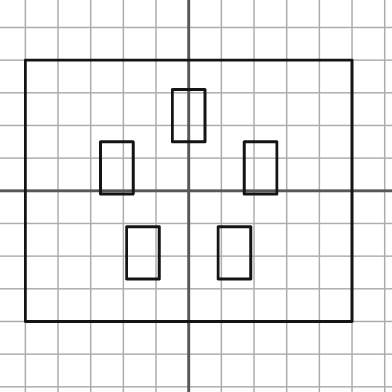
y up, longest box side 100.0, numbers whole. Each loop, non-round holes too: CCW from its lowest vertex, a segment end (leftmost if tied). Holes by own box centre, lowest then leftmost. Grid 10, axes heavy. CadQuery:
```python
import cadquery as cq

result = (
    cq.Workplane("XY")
    .moveTo(-50.0, -40.0)
    .lineTo(50.0, -40.0)
    .lineTo(50.0, 40.0)
    .lineTo(-50.0, 40.0)
    .close()
    .moveTo(-19.0, -27.0)
    .lineTo(-9.0, -27.0)
    .lineTo(-9.0, -11.0)
    .lineTo(-19.0, -11.0)
    .close()
    .moveTo(9.0, -27.0)
    .lineTo(19.0, -27.0)
    .lineTo(19.0, -11.0)
    .lineTo(9.0, -11.0)
    .close()
    .moveTo(-27.0, -1.0)
    .lineTo(-17.0, -1.0)
    .lineTo(-17.0, 15.0)
    .lineTo(-27.0, 15.0)
    .close()
    .moveTo(17.0, -1.0)
    .lineTo(27.0, -1.0)
    .lineTo(27.0, 15.0)
    .lineTo(17.0, 15.0)
    .close()
    .moveTo(-5.0, 15.0)
    .lineTo(5.0, 15.0)
    .lineTo(5.0, 31.0)
    .lineTo(-5.0, 31.0)
    .close()
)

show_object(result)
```